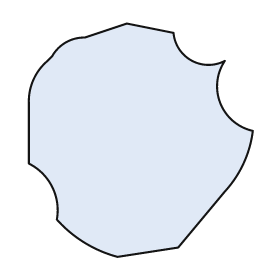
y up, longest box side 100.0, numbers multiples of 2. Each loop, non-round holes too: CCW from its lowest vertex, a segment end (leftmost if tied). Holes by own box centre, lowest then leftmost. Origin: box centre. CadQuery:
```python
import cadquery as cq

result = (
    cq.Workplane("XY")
    .moveTo(-10.0, -50.0)
    .lineTo(16.0, -46.0)
    .lineTo(36.0, -22.0)
    .threePointArc((44.0, -10.0), (48.0, 4.0))
    .threePointArc((34.0, 16.0), (36.0, 34.0))
    .threePointArc((22.0, 34.0), (14.0, 46.0))
    .lineTo(-6.0, 50.0)
    .lineTo(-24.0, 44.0)
    .threePointArc((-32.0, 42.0), (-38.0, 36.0))
    .lineTo(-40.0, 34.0)
    .threePointArc((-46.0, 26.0), (-48.0, 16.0))
    .lineTo(-48.0, -10.0)
    .threePointArc((-38.0, -20.0), (-36.0, -34.0))
    .threePointArc((-24.0, -44.0), (-10.0, -50.0))
    .close()
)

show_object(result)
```